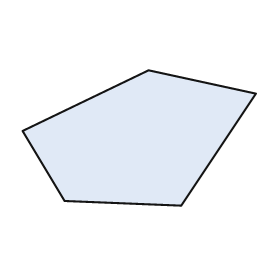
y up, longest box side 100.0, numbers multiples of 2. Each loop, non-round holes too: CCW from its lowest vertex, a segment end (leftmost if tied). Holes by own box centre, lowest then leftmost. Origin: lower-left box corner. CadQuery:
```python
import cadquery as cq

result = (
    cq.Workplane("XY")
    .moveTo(68.0, 0.0)
    .lineTo(100.0, 48.0)
    .lineTo(54.0, 58.0)
    .lineTo(0.0, 32.0)
    .lineTo(18.0, 2.0)
    .close()
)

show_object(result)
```